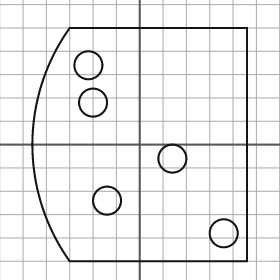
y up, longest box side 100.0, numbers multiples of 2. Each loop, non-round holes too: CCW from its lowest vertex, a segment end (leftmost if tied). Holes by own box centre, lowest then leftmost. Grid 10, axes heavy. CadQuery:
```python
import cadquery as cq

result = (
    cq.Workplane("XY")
    .moveTo(-30.0, -50.0)
    .lineTo(46.0, -50.0)
    .lineTo(46.0, 50.0)
    .lineTo(-30.0, 50.0)
    .threePointArc((-46.0, 0.0), (-30.0, -50.0))
    .close()
    .moveTo(36.0, -38.0)
    .circle(6.0)
    .moveTo(-14.0, -24.0)
    .circle(6.0)
    .moveTo(14.0, -6.0)
    .circle(6.0)
    .moveTo(-20.0, 18.0)
    .circle(6.0)
    .moveTo(-22.0, 34.0)
    .circle(6.0)
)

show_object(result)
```